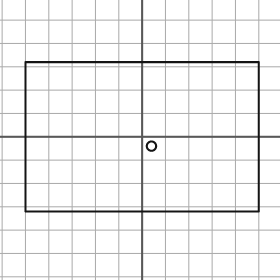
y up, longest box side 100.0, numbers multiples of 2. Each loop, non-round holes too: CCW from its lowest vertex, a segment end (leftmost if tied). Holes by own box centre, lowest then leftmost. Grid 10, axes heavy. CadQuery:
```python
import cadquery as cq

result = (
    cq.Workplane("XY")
    .moveTo(-50.0, -32.0)
    .lineTo(50.0, -32.0)
    .lineTo(50.0, 32.0)
    .lineTo(-50.0, 32.0)
    .close()
    .moveTo(4.0, -4.0)
    .circle(2.0)
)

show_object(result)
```